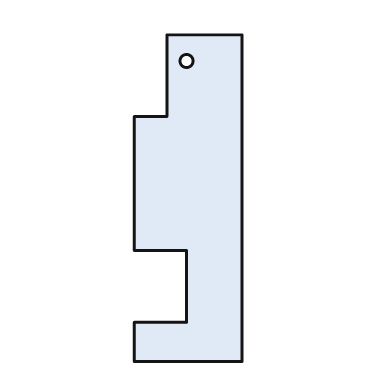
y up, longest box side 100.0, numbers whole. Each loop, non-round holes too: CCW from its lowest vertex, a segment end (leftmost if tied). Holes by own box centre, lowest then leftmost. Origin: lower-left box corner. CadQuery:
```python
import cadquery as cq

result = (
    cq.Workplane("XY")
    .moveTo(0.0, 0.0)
    .lineTo(33.0, 0.0)
    .lineTo(33.0, 100.0)
    .lineTo(10.0, 100.0)
    .lineTo(10.0, 75.0)
    .lineTo(0.0, 75.0)
    .lineTo(0.0, 34.0)
    .lineTo(16.0, 34.0)
    .lineTo(16.0, 12.0)
    .lineTo(0.0, 12.0)
    .close()
    .moveTo(16.0, 92.0)
    .circle(2.0)
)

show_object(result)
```